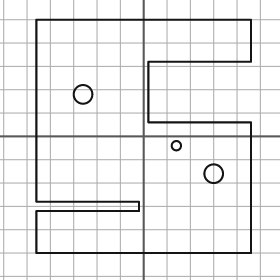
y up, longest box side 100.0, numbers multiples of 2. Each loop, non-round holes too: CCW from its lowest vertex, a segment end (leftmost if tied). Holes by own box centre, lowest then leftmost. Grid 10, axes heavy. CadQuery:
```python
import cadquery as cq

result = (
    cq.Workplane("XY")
    .moveTo(-46.0, -50.0)
    .lineTo(46.0, -50.0)
    .lineTo(46.0, 6.0)
    .lineTo(2.0, 6.0)
    .lineTo(2.0, 32.0)
    .lineTo(46.0, 32.0)
    .lineTo(46.0, 50.0)
    .lineTo(-46.0, 50.0)
    .lineTo(-46.0, -28.0)
    .lineTo(-2.0, -28.0)
    .lineTo(-2.0, -32.0)
    .lineTo(-46.0, -32.0)
    .close()
    .moveTo(30.0, -16.0)
    .circle(4.0)
    .moveTo(14.0, -4.0)
    .circle(2.0)
    .moveTo(-26.0, 18.0)
    .circle(4.0)
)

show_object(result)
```